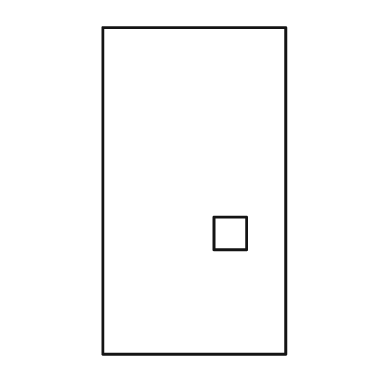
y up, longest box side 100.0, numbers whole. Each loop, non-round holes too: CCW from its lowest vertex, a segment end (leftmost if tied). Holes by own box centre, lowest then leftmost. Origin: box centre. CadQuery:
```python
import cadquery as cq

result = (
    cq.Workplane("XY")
    .moveTo(-28.0, -50.0)
    .lineTo(28.0, -50.0)
    .lineTo(28.0, 50.0)
    .lineTo(-28.0, 50.0)
    .close()
    .moveTo(6.0, -18.0)
    .lineTo(16.0, -18.0)
    .lineTo(16.0, -8.0)
    .lineTo(6.0, -8.0)
    .close()
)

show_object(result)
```